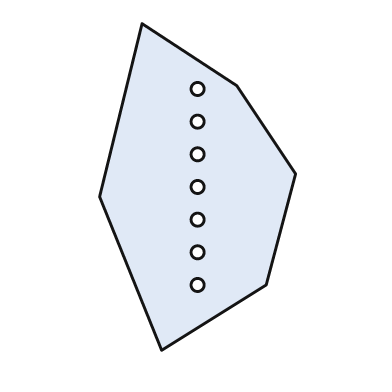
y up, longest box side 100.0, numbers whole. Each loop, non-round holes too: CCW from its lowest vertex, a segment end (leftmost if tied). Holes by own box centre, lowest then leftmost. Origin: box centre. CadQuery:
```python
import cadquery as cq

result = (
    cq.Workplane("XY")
    .moveTo(-11.0, -50.0)
    .lineTo(21.0, -30.0)
    .lineTo(30.0, 4.0)
    .lineTo(12.0, 31.0)
    .lineTo(-17.0, 50.0)
    .lineTo(-30.0, -3.0)
    .close()
    .moveTo(0.0, -30.0)
    .circle(2.0)
    .moveTo(0.0, -20.0)
    .circle(2.0)
    .moveTo(0.0, -10.0)
    .circle(2.0)
    .moveTo(0.0, 0.0)
    .circle(2.0)
    .moveTo(0.0, 10.0)
    .circle(2.0)
    .moveTo(0.0, 20.0)
    .circle(2.0)
    .moveTo(0.0, 30.0)
    .circle(2.0)
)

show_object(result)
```